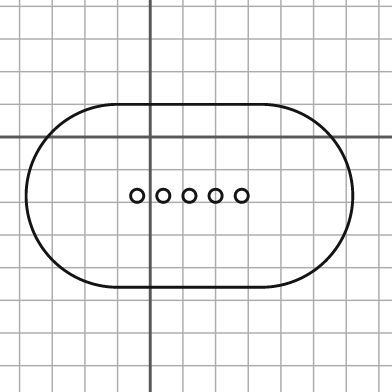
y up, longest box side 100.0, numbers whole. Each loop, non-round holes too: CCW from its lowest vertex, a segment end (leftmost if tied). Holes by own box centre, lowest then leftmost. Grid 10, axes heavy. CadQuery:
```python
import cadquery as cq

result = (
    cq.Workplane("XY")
    .moveTo(-10.0, -46.0)
    .lineTo(34.0, -46.0)
    .threePointArc((62.0, -18.0), (34.0, 10.0))
    .lineTo(-10.0, 10.0)
    .threePointArc((-38.0, -18.0), (-10.0, -46.0))
    .close()
    .moveTo(-4.0, -18.0)
    .circle(2.0)
    .moveTo(4.0, -18.0)
    .circle(2.0)
    .moveTo(12.0, -18.0)
    .circle(2.0)
    .moveTo(20.0, -18.0)
    .circle(2.0)
    .moveTo(28.0, -18.0)
    .circle(2.0)
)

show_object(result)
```